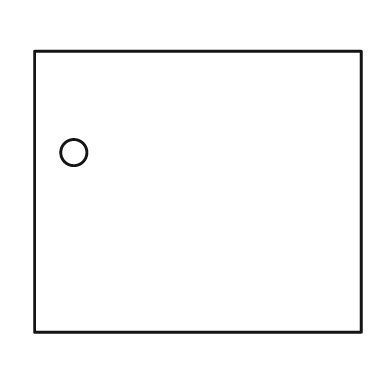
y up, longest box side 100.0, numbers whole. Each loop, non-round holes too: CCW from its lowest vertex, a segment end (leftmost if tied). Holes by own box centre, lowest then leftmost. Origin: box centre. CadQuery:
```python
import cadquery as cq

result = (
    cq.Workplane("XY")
    .moveTo(-50.0, -43.0)
    .lineTo(50.0, -43.0)
    .lineTo(50.0, 43.0)
    .lineTo(-50.0, 43.0)
    .close()
    .moveTo(-38.0, 12.0)
    .circle(4.0)
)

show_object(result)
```